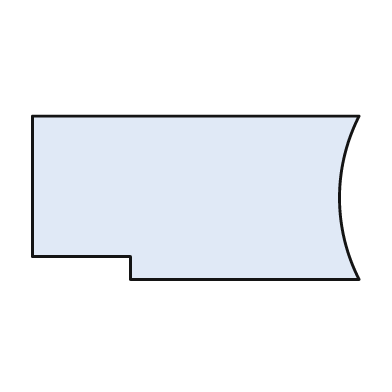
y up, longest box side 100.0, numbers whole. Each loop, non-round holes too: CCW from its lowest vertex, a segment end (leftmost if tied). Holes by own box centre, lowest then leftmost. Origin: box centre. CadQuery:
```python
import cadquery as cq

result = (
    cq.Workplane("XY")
    .moveTo(-20.0, -25.0)
    .lineTo(50.0, -25.0)
    .threePointArc((44.0, 0.0), (50.0, 25.0))
    .lineTo(-50.0, 25.0)
    .lineTo(-50.0, -18.0)
    .lineTo(-20.0, -18.0)
    .close()
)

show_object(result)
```